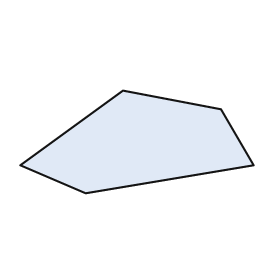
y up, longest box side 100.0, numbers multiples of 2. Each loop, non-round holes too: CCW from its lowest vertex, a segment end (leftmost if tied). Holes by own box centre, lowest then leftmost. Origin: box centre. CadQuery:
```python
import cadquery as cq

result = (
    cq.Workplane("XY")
    .moveTo(-22.0, -22.0)
    .lineTo(50.0, -10.0)
    .lineTo(36.0, 14.0)
    .lineTo(-6.0, 22.0)
    .lineTo(-50.0, -10.0)
    .close()
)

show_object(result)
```